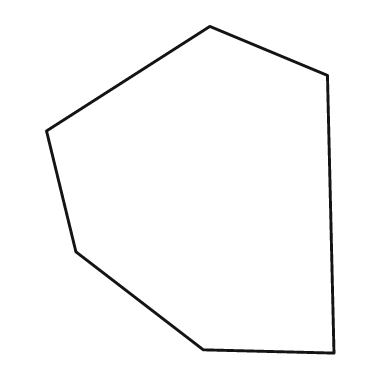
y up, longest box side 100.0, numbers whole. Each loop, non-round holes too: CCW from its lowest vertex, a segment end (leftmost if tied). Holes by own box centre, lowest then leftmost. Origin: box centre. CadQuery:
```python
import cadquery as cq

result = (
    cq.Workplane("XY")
    .moveTo(44.0, -50.0)
    .lineTo(42.0, 35.0)
    .lineTo(6.0, 50.0)
    .lineTo(-44.0, 18.0)
    .lineTo(-35.0, -19.0)
    .lineTo(4.0, -49.0)
    .close()
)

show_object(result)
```